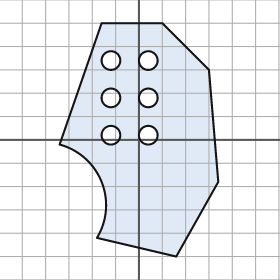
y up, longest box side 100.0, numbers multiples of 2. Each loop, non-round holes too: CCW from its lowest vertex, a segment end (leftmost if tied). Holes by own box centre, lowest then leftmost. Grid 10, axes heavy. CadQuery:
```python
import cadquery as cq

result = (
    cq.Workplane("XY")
    .moveTo(16.0, -50.0)
    .lineTo(34.0, -18.0)
    .lineTo(30.0, 30.0)
    .lineTo(10.0, 50.0)
    .lineTo(-16.0, 50.0)
    .lineTo(-34.0, -2.0)
    .threePointArc((-16.0, -18.0), (-18.0, -42.0))
    .close()
    .moveTo(-12.0, 2.0)
    .circle(4.0)
    .moveTo(4.0, 2.0)
    .circle(4.0)
    .moveTo(-12.0, 18.0)
    .circle(4.0)
    .moveTo(4.0, 18.0)
    .circle(4.0)
    .moveTo(-12.0, 34.0)
    .circle(4.0)
    .moveTo(4.0, 34.0)
    .circle(4.0)
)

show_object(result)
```